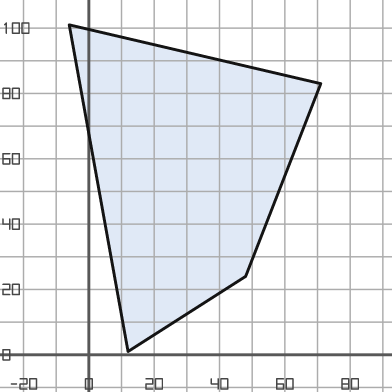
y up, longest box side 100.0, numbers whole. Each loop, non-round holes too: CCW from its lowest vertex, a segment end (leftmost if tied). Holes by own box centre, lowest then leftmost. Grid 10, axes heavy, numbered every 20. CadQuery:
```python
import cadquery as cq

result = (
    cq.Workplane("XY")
    .moveTo(12.0, 1.0)
    .lineTo(48.0, 24.0)
    .lineTo(71.0, 83.0)
    .lineTo(-6.0, 101.0)
    .close()
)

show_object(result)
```